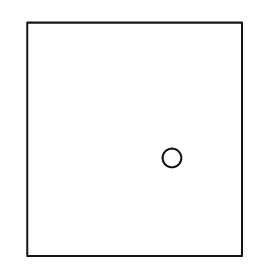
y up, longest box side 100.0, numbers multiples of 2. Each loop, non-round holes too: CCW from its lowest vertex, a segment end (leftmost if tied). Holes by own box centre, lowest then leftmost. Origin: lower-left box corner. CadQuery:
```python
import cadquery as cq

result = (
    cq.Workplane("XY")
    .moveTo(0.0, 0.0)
    .lineTo(92.0, 0.0)
    .lineTo(92.0, 100.0)
    .lineTo(0.0, 100.0)
    .close()
    .moveTo(62.0, 42.0)
    .circle(4.0)
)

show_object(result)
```